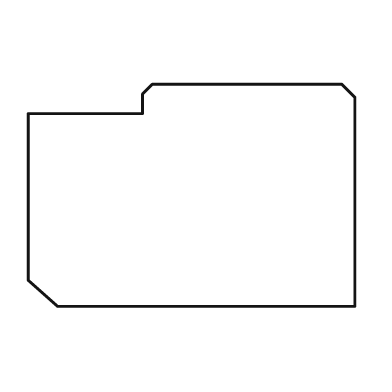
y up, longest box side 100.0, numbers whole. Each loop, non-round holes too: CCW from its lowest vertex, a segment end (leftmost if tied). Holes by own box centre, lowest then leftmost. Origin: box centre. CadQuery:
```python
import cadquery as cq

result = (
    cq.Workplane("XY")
    .moveTo(-41.0, -34.0)
    .lineTo(50.0, -34.0)
    .lineTo(50.0, 30.0)
    .lineTo(46.0, 34.0)
    .lineTo(-12.0, 34.0)
    .lineTo(-15.0, 31.0)
    .lineTo(-15.0, 25.0)
    .lineTo(-50.0, 25.0)
    .lineTo(-50.0, -26.0)
    .close()
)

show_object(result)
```